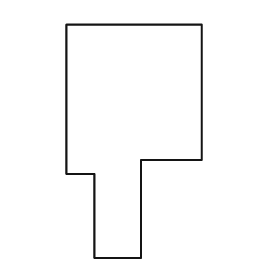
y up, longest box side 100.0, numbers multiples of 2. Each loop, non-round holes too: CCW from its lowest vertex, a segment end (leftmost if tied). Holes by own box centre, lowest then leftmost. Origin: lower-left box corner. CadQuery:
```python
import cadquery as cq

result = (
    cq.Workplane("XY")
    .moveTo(12.0, 0.0)
    .lineTo(32.0, 0.0)
    .lineTo(32.0, 42.0)
    .lineTo(58.0, 42.0)
    .lineTo(58.0, 100.0)
    .lineTo(0.0, 100.0)
    .lineTo(0.0, 36.0)
    .lineTo(12.0, 36.0)
    .close()
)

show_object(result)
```